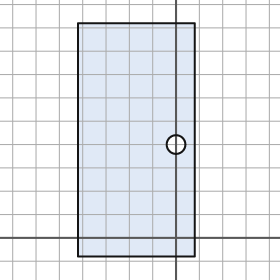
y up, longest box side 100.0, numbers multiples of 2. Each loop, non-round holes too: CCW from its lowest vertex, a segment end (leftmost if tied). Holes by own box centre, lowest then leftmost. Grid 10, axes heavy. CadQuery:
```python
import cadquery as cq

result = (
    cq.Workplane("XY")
    .moveTo(-42.0, -8.0)
    .lineTo(8.0, -8.0)
    .lineTo(8.0, 92.0)
    .lineTo(-42.0, 92.0)
    .close()
    .moveTo(0.0, 40.0)
    .circle(4.0)
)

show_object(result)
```